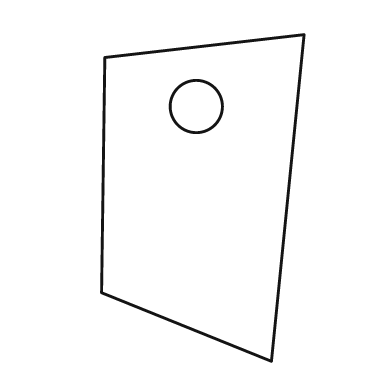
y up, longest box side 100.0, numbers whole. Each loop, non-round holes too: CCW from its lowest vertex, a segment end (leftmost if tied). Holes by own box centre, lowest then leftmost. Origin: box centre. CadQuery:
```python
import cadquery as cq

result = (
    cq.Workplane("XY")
    .moveTo(21.0, -50.0)
    .lineTo(31.0, 50.0)
    .lineTo(-30.0, 43.0)
    .lineTo(-31.0, -29.0)
    .close()
    .moveTo(-2.0, 28.0)
    .circle(8.0)
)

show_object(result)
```